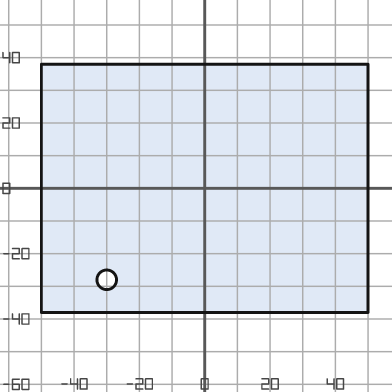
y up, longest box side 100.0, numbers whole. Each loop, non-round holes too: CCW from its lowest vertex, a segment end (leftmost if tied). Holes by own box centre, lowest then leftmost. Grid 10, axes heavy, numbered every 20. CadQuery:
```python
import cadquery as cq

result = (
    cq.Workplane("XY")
    .moveTo(-50.0, -38.0)
    .lineTo(50.0, -38.0)
    .lineTo(50.0, 38.0)
    .lineTo(-50.0, 38.0)
    .close()
    .moveTo(-30.0, -28.0)
    .circle(3.0)
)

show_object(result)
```